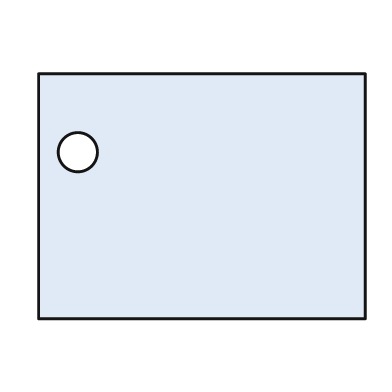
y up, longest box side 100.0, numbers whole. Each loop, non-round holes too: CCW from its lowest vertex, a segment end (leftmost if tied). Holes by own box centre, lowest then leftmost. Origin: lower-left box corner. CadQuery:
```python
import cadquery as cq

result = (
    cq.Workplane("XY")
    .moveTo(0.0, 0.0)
    .lineTo(100.0, 0.0)
    .lineTo(100.0, 75.0)
    .lineTo(0.0, 75.0)
    .close()
    .moveTo(12.0, 51.0)
    .circle(6.0)
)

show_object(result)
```